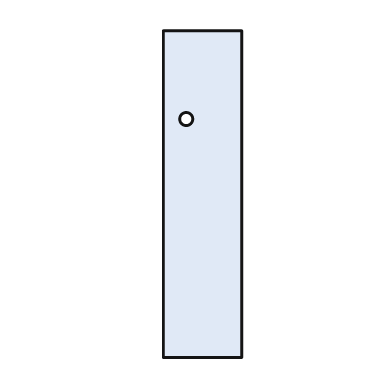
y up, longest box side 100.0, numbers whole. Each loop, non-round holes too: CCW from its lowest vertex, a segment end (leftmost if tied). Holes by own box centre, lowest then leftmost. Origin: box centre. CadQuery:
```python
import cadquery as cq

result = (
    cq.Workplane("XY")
    .moveTo(-12.0, -50.0)
    .lineTo(12.0, -50.0)
    .lineTo(12.0, 50.0)
    .lineTo(-12.0, 50.0)
    .close()
    .moveTo(-5.0, 23.0)
    .circle(2.0)
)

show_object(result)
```